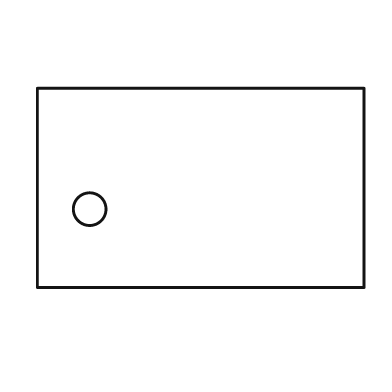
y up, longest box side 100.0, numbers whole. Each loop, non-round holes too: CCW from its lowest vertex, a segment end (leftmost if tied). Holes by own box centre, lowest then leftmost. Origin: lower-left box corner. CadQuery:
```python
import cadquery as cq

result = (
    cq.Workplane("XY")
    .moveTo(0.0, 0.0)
    .lineTo(100.0, 0.0)
    .lineTo(100.0, 61.0)
    .lineTo(0.0, 61.0)
    .close()
    .moveTo(16.0, 24.0)
    .circle(5.0)
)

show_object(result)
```